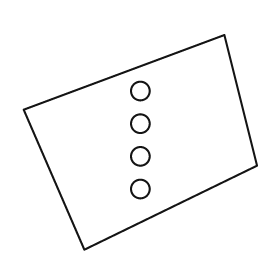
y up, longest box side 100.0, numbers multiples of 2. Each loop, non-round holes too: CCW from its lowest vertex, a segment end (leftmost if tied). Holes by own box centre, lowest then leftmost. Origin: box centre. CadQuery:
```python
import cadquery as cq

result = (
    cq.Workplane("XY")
    .moveTo(-24.0, -46.0)
    .lineTo(50.0, -10.0)
    .lineTo(36.0, 46.0)
    .lineTo(-50.0, 14.0)
    .close()
    .moveTo(0.0, -20.0)
    .circle(4.0)
    .moveTo(0.0, -6.0)
    .circle(4.0)
    .moveTo(0.0, 8.0)
    .circle(4.0)
    .moveTo(0.0, 22.0)
    .circle(4.0)
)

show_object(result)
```